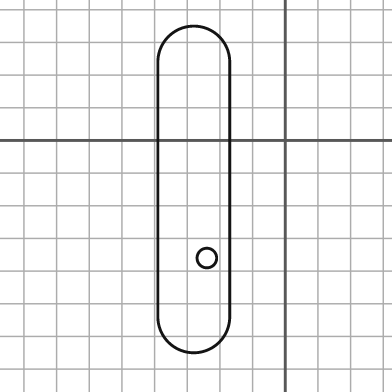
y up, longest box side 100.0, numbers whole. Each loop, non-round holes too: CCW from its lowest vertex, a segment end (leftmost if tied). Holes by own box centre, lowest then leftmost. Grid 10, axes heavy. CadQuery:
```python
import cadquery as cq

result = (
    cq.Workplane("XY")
    .moveTo(-39.0, -54.0)
    .threePointArc((-28.0, -65.0), (-17.0, -54.0))
    .lineTo(-17.0, 24.0)
    .threePointArc((-28.0, 35.0), (-39.0, 24.0))
    .close()
    .moveTo(-24.0, -36.0)
    .circle(3.0)
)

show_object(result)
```